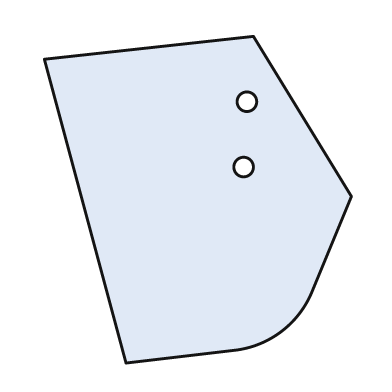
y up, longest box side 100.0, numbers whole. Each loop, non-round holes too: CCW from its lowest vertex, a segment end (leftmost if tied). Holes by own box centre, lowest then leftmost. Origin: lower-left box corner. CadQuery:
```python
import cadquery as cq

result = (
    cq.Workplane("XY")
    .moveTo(25.0, 0.0)
    .lineTo(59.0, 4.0)
    .threePointArc((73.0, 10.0), (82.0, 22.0))
    .lineTo(94.0, 51.0)
    .lineTo(64.0, 100.0)
    .lineTo(0.0, 93.0)
    .close()
    .moveTo(61.0, 60.0)
    .circle(3.0)
    .moveTo(62.0, 80.0)
    .circle(3.0)
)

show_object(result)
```